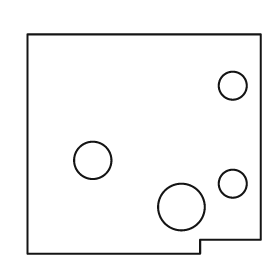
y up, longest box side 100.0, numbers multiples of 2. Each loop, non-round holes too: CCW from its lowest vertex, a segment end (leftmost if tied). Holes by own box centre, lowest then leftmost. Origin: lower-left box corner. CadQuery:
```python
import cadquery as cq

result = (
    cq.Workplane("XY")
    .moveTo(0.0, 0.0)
    .lineTo(74.0, 0.0)
    .lineTo(74.0, 6.0)
    .lineTo(100.0, 6.0)
    .lineTo(100.0, 94.0)
    .lineTo(0.0, 94.0)
    .close()
    .moveTo(66.0, 20.0)
    .circle(10.0)
    .moveTo(88.0, 30.0)
    .circle(6.0)
    .moveTo(28.0, 40.0)
    .circle(8.0)
    .moveTo(88.0, 72.0)
    .circle(6.0)
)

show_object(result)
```